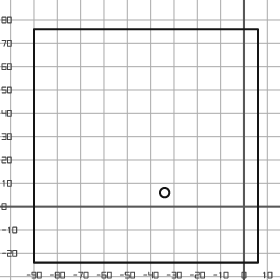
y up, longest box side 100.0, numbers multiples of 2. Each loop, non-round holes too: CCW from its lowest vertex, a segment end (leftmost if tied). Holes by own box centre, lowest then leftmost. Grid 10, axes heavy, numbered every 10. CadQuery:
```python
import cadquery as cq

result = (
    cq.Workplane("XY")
    .moveTo(-90.0, -24.0)
    .lineTo(6.0, -24.0)
    .lineTo(6.0, 76.0)
    .lineTo(-90.0, 76.0)
    .close()
    .moveTo(-34.0, 6.0)
    .circle(2.0)
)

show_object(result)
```